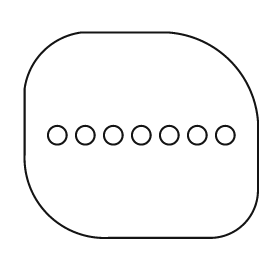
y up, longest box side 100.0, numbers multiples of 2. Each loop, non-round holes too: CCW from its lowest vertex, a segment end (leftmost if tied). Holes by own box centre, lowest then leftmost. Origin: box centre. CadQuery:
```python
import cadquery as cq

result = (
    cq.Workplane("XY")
    .moveTo(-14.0, -44.0)
    .lineTo(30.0, -44.0)
    .threePointArc((44.0, -38.0), (50.0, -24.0))
    .lineTo(50.0, 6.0)
    .threePointArc((38.0, 32.0), (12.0, 44.0))
    .lineTo(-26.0, 44.0)
    .threePointArc((-42.0, 36.0), (-50.0, 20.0))
    .lineTo(-50.0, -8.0)
    .threePointArc((-40.0, -34.0), (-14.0, -44.0))
    .close()
    .moveTo(-36.0, 0.0)
    .circle(4.0)
    .moveTo(-24.0, 0.0)
    .circle(4.0)
    .moveTo(-12.0, 0.0)
    .circle(4.0)
    .moveTo(0.0, 0.0)
    .circle(4.0)
    .moveTo(12.0, 0.0)
    .circle(4.0)
    .moveTo(24.0, 0.0)
    .circle(4.0)
    .moveTo(36.0, 0.0)
    .circle(4.0)
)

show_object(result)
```